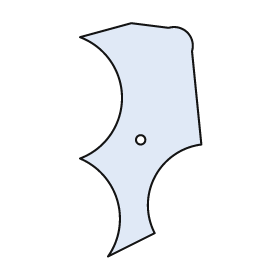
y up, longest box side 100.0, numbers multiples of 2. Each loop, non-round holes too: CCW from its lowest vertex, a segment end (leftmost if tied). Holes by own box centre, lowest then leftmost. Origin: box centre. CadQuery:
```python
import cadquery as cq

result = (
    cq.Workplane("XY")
    .moveTo(-14.0, -50.0)
    .lineTo(6.0, -40.0)
    .threePointArc((6.0, -16.0), (26.0, -2.0))
    .lineTo(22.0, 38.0)
    .threePointArc((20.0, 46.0), (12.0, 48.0))
    .lineTo(-4.0, 50.0)
    .lineTo(-26.0, 44.0)
    .threePointArc((-8.0, 18.0), (-26.0, -8.0))
    .threePointArc((-10.0, -26.0), (-14.0, -50.0))
    .close()
    .moveTo(0.0, 0.0)
    .circle(2.0)
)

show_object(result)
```